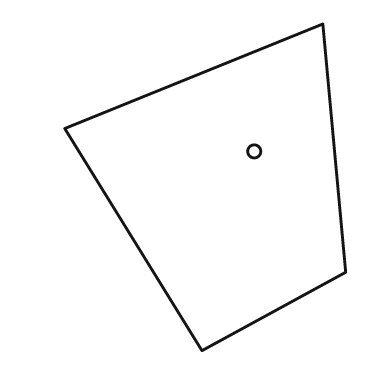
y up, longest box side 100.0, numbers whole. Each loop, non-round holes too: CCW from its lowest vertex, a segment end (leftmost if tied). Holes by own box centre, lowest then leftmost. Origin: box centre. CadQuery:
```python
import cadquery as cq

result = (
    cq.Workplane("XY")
    .moveTo(-1.0, -50.0)
    .lineTo(43.0, -26.0)
    .lineTo(36.0, 50.0)
    .lineTo(-43.0, 18.0)
    .close()
    .moveTo(15.0, 11.0)
    .circle(2.0)
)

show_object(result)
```